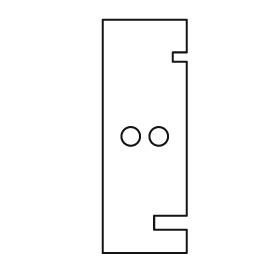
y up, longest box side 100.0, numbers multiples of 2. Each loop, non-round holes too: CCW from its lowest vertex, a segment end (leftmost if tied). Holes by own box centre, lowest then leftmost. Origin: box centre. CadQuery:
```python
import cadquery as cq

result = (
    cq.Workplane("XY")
    .moveTo(-18.0, -50.0)
    .lineTo(18.0, -50.0)
    .lineTo(18.0, -40.0)
    .lineTo(4.0, -40.0)
    .lineTo(4.0, -34.0)
    .lineTo(18.0, -34.0)
    .lineTo(18.0, 32.0)
    .lineTo(12.0, 32.0)
    .lineTo(12.0, 36.0)
    .lineTo(18.0, 36.0)
    .lineTo(18.0, 50.0)
    .lineTo(-18.0, 50.0)
    .close()
    .moveTo(-6.0, 0.0)
    .circle(4.0)
    .moveTo(6.0, 0.0)
    .circle(4.0)
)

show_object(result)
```